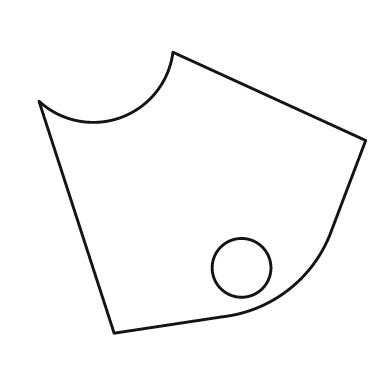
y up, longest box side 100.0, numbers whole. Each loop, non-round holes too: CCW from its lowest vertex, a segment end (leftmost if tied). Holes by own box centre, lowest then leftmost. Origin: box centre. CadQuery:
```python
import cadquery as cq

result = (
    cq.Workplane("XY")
    .moveTo(-27.0, -43.0)
    .lineTo(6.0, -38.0)
    .threePointArc((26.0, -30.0), (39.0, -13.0))
    .lineTo(50.0, 16.0)
    .lineTo(-9.0, 43.0)
    .threePointArc((-25.0, 23.0), (-50.0, 28.0))
    .close()
    .moveTo(12.0, -23.0)
    .circle(9.0)
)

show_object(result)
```